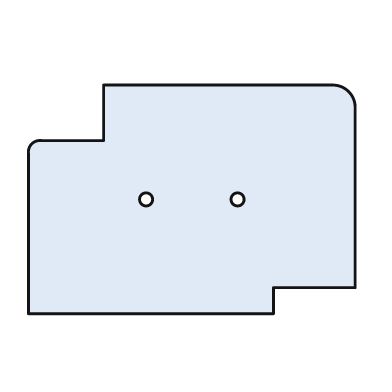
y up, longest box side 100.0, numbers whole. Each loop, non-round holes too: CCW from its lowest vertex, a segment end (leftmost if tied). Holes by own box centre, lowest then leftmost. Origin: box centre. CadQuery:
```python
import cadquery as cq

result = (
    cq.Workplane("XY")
    .moveTo(-50.0, -35.0)
    .lineTo(25.0, -35.0)
    .lineTo(25.0, -27.0)
    .lineTo(50.0, -27.0)
    .lineTo(50.0, 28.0)
    .threePointArc((48.0, 33.0), (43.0, 35.0))
    .lineTo(-27.0, 35.0)
    .lineTo(-27.0, 18.0)
    .lineTo(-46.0, 18.0)
    .threePointArc((-49.0, 17.0), (-50.0, 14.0))
    .close()
    .moveTo(-14.0, 0.0)
    .circle(2.0)
    .moveTo(14.0, 0.0)
    .circle(2.0)
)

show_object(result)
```